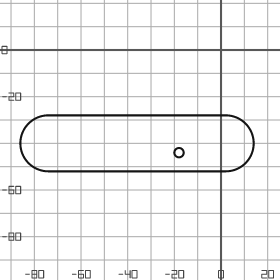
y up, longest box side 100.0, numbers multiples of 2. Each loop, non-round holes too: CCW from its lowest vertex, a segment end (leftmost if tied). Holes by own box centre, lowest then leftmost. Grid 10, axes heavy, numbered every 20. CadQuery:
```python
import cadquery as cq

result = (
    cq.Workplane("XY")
    .moveTo(-74.0, -52.0)
    .lineTo(2.0, -52.0)
    .threePointArc((14.0, -40.0), (2.0, -28.0))
    .lineTo(-74.0, -28.0)
    .threePointArc((-86.0, -40.0), (-74.0, -52.0))
    .close()
    .moveTo(-18.0, -44.0)
    .circle(2.0)
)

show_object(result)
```